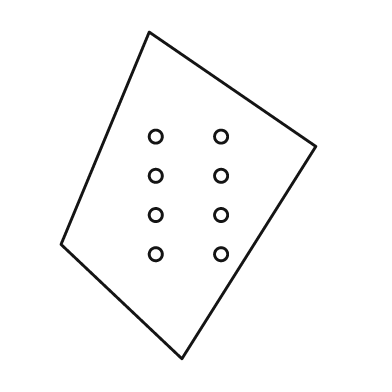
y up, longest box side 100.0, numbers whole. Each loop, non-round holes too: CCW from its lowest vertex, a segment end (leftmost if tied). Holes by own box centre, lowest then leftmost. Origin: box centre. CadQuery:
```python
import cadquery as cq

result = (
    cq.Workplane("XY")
    .moveTo(-2.0, -50.0)
    .lineTo(39.0, 15.0)
    .lineTo(-12.0, 50.0)
    .lineTo(-39.0, -15.0)
    .close()
    .moveTo(-10.0, -18.0)
    .circle(2.0)
    .moveTo(10.0, -18.0)
    .circle(2.0)
    .moveTo(-10.0, -6.0)
    .circle(2.0)
    .moveTo(10.0, -6.0)
    .circle(2.0)
    .moveTo(-10.0, 6.0)
    .circle(2.0)
    .moveTo(10.0, 6.0)
    .circle(2.0)
    .moveTo(-10.0, 18.0)
    .circle(2.0)
    .moveTo(10.0, 18.0)
    .circle(2.0)
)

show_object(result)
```